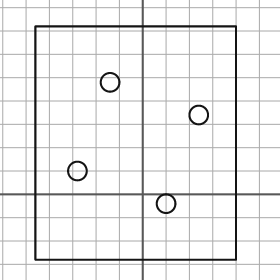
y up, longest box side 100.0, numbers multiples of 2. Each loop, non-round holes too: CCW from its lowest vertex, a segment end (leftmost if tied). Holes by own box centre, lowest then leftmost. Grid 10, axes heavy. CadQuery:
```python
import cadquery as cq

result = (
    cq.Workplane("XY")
    .moveTo(-46.0, -28.0)
    .lineTo(40.0, -28.0)
    .lineTo(40.0, 72.0)
    .lineTo(-46.0, 72.0)
    .close()
    .moveTo(10.0, -4.0)
    .circle(4.0)
    .moveTo(-28.0, 10.0)
    .circle(4.0)
    .moveTo(24.0, 34.0)
    .circle(4.0)
    .moveTo(-14.0, 48.0)
    .circle(4.0)
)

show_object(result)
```